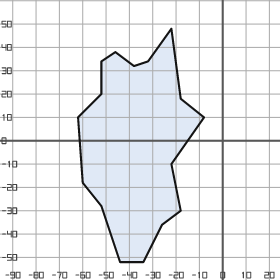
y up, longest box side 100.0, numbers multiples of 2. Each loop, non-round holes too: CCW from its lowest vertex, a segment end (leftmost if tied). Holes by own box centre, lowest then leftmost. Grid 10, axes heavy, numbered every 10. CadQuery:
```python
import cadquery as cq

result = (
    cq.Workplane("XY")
    .moveTo(-44.0, -52.0)
    .lineTo(-34.0, -52.0)
    .lineTo(-26.0, -36.0)
    .lineTo(-18.0, -30.0)
    .lineTo(-22.0, -10.0)
    .lineTo(-8.0, 10.0)
    .lineTo(-18.0, 18.0)
    .lineTo(-22.0, 48.0)
    .lineTo(-32.0, 34.0)
    .lineTo(-38.0, 32.0)
    .lineTo(-46.0, 38.0)
    .lineTo(-52.0, 34.0)
    .lineTo(-52.0, 20.0)
    .lineTo(-62.0, 10.0)
    .lineTo(-60.0, -18.0)
    .lineTo(-52.0, -28.0)
    .close()
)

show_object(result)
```